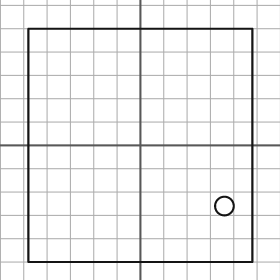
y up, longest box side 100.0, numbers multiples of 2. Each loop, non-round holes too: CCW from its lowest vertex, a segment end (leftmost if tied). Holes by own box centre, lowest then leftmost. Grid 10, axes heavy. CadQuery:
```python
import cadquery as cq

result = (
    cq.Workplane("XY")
    .moveTo(-48.0, -50.0)
    .lineTo(48.0, -50.0)
    .lineTo(48.0, 50.0)
    .lineTo(-48.0, 50.0)
    .close()
    .moveTo(36.0, -26.0)
    .circle(4.0)
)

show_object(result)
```